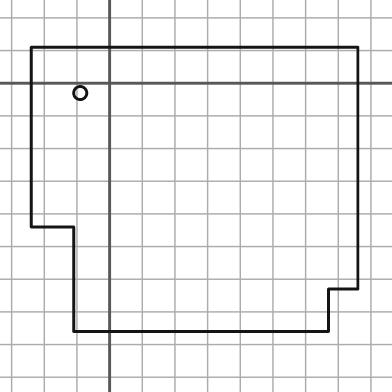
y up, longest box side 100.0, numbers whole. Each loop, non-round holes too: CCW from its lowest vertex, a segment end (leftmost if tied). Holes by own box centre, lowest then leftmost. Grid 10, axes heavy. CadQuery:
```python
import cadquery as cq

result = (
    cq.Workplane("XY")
    .moveTo(-11.0, -76.0)
    .lineTo(67.0, -76.0)
    .lineTo(67.0, -63.0)
    .lineTo(76.0, -63.0)
    .lineTo(76.0, 11.0)
    .lineTo(-24.0, 11.0)
    .lineTo(-24.0, -44.0)
    .lineTo(-11.0, -44.0)
    .close()
    .moveTo(-9.0, -3.0)
    .circle(2.0)
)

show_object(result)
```